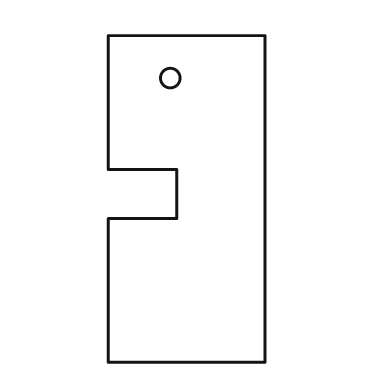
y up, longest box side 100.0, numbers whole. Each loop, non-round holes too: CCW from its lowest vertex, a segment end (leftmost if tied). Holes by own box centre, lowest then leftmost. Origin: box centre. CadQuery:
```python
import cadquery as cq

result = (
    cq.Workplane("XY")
    .moveTo(-24.0, -50.0)
    .lineTo(24.0, -50.0)
    .lineTo(24.0, 50.0)
    .lineTo(-24.0, 50.0)
    .lineTo(-24.0, 9.0)
    .lineTo(-3.0, 9.0)
    .lineTo(-3.0, -6.0)
    .lineTo(-24.0, -6.0)
    .close()
    .moveTo(-5.0, 37.0)
    .circle(3.0)
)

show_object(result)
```